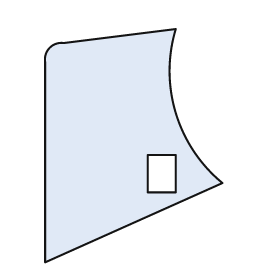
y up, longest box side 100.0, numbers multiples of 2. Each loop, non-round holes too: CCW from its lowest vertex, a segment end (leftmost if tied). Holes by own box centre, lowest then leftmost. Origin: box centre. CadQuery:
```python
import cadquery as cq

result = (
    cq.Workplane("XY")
    .moveTo(-38.0, -50.0)
    .lineTo(38.0, -16.0)
    .threePointArc((18.0, 14.0), (18.0, 50.0))
    .lineTo(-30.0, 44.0)
    .threePointArc((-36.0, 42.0), (-38.0, 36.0))
    .close()
    .moveTo(6.0, -20.0)
    .lineTo(18.0, -20.0)
    .lineTo(18.0, -4.0)
    .lineTo(6.0, -4.0)
    .close()
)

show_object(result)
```